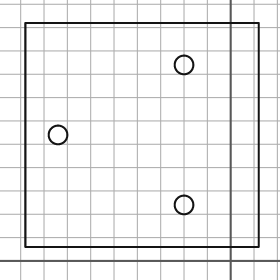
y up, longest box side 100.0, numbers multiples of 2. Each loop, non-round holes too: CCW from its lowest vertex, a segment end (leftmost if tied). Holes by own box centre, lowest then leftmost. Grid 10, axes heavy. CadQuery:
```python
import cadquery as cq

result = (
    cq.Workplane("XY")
    .moveTo(-88.0, 6.0)
    .lineTo(12.0, 6.0)
    .lineTo(12.0, 102.0)
    .lineTo(-88.0, 102.0)
    .close()
    .moveTo(-20.0, 24.0)
    .circle(4.0)
    .moveTo(-74.0, 54.0)
    .circle(4.0)
    .moveTo(-20.0, 84.0)
    .circle(4.0)
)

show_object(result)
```